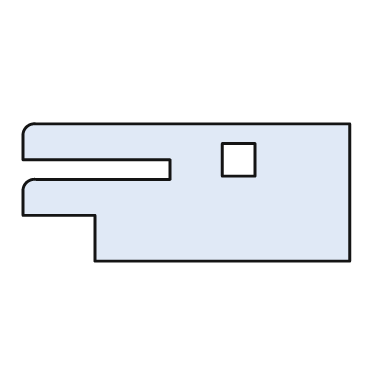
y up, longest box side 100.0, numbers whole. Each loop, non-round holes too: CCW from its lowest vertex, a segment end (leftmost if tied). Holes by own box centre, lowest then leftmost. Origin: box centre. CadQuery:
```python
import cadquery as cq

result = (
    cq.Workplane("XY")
    .moveTo(-28.0, -21.0)
    .lineTo(50.0, -21.0)
    .lineTo(50.0, 21.0)
    .lineTo(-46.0, 21.0)
    .threePointArc((-49.0, 20.0), (-50.0, 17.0))
    .lineTo(-50.0, 10.0)
    .lineTo(-5.0, 10.0)
    .lineTo(-5.0, 4.0)
    .lineTo(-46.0, 4.0)
    .threePointArc((-49.0, 3.0), (-50.0, 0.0))
    .lineTo(-50.0, -7.0)
    .lineTo(-28.0, -7.0)
    .close()
    .moveTo(11.0, 5.0)
    .lineTo(21.0, 5.0)
    .lineTo(21.0, 15.0)
    .lineTo(11.0, 15.0)
    .close()
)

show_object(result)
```